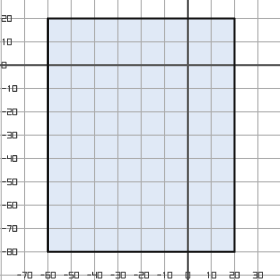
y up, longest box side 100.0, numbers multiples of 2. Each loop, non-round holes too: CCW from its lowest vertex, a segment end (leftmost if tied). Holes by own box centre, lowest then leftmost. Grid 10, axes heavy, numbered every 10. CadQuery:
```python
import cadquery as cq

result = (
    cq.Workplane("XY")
    .moveTo(-60.0, -80.0)
    .lineTo(20.0, -80.0)
    .lineTo(20.0, 20.0)
    .lineTo(-60.0, 20.0)
    .close()
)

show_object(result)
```